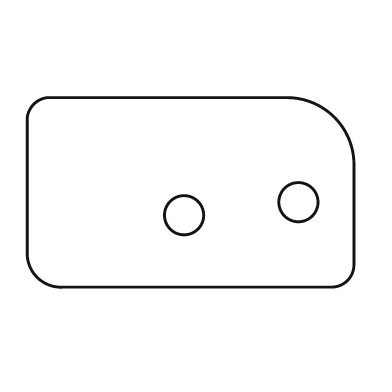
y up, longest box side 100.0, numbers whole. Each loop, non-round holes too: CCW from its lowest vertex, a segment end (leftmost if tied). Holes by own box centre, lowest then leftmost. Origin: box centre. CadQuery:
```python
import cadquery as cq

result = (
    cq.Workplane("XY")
    .moveTo(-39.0, -29.0)
    .lineTo(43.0, -29.0)
    .threePointArc((48.0, -27.0), (50.0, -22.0))
    .lineTo(50.0, 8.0)
    .threePointArc((44.0, 23.0), (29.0, 29.0))
    .lineTo(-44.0, 29.0)
    .threePointArc((-48.0, 27.0), (-50.0, 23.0))
    .lineTo(-50.0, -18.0)
    .threePointArc((-47.0, -26.0), (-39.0, -29.0))
    .close()
    .moveTo(-2.0, -7.0)
    .circle(6.0)
    .moveTo(33.0, -3.0)
    .circle(6.0)
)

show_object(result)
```